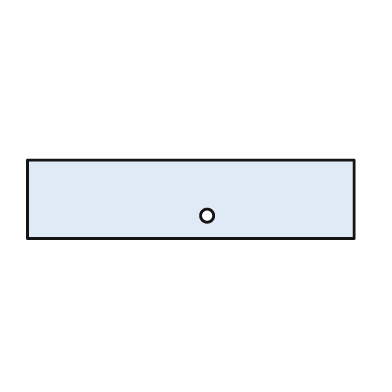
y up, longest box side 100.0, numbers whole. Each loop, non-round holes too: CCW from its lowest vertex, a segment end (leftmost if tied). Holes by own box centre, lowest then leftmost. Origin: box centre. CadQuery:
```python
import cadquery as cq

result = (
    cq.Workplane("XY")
    .moveTo(-50.0, -12.0)
    .lineTo(50.0, -12.0)
    .lineTo(50.0, 12.0)
    .lineTo(-50.0, 12.0)
    .close()
    .moveTo(5.0, -5.0)
    .circle(2.0)
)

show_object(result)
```